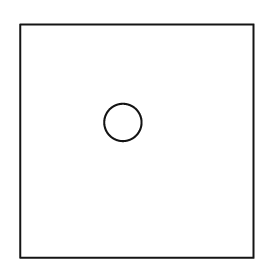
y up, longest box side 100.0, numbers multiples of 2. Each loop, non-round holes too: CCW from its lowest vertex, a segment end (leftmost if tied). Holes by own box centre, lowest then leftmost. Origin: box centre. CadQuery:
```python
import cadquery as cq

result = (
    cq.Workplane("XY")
    .moveTo(-50.0, -50.0)
    .lineTo(50.0, -50.0)
    .lineTo(50.0, 50.0)
    .lineTo(-50.0, 50.0)
    .close()
    .moveTo(-6.0, 8.0)
    .circle(8.0)
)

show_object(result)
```